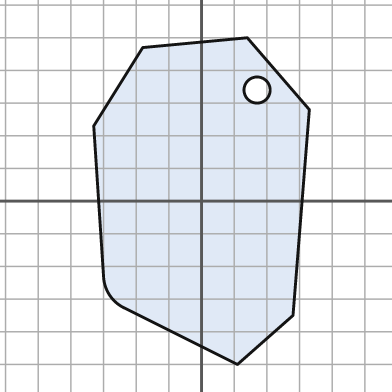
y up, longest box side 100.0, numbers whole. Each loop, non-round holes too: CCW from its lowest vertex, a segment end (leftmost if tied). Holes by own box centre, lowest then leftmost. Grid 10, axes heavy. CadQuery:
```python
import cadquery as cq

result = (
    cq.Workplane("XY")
    .moveTo(11.0, -50.0)
    .lineTo(28.0, -35.0)
    .lineTo(33.0, 28.0)
    .lineTo(14.0, 50.0)
    .lineTo(-18.0, 47.0)
    .lineTo(-33.0, 23.0)
    .lineTo(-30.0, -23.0)
    .threePointArc((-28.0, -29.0), (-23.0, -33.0))
    .close()
    .moveTo(17.0, 34.0)
    .circle(4.0)
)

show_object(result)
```